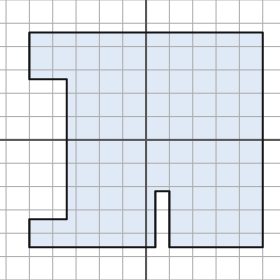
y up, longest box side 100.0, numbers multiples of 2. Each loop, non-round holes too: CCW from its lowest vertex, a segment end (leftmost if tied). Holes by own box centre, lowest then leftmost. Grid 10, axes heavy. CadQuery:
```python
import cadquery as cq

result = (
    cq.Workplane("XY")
    .moveTo(-50.0, -46.0)
    .lineTo(4.0, -46.0)
    .lineTo(4.0, -22.0)
    .lineTo(10.0, -22.0)
    .lineTo(10.0, -46.0)
    .lineTo(50.0, -46.0)
    .lineTo(50.0, 46.0)
    .lineTo(-50.0, 46.0)
    .lineTo(-50.0, 26.0)
    .lineTo(-34.0, 26.0)
    .lineTo(-34.0, -34.0)
    .lineTo(-50.0, -34.0)
    .close()
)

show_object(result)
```